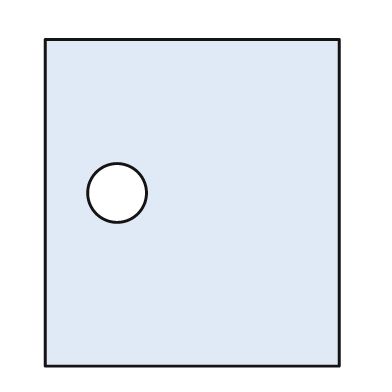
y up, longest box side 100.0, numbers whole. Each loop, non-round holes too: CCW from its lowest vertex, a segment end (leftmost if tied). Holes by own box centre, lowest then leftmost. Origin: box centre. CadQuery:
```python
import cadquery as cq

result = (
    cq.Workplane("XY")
    .moveTo(-45.0, -50.0)
    .lineTo(45.0, -50.0)
    .lineTo(45.0, 50.0)
    .lineTo(-45.0, 50.0)
    .close()
    .moveTo(-23.0, 3.0)
    .circle(9.0)
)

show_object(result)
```